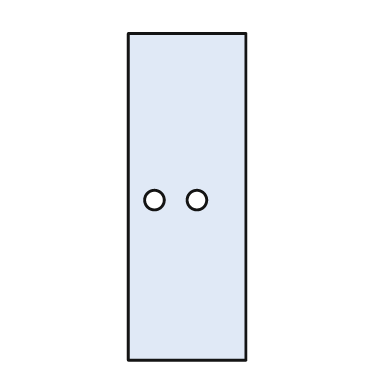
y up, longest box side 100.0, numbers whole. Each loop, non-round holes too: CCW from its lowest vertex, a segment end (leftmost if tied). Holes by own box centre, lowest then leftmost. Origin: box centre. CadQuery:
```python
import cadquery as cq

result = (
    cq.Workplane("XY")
    .moveTo(-18.0, -50.0)
    .lineTo(18.0, -50.0)
    .lineTo(18.0, 50.0)
    .lineTo(-18.0, 50.0)
    .close()
    .moveTo(-10.0, -1.0)
    .circle(3.0)
    .moveTo(3.0, -1.0)
    .circle(3.0)
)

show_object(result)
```